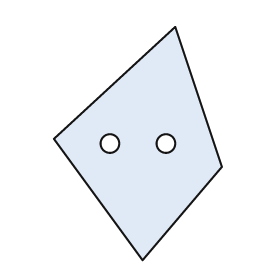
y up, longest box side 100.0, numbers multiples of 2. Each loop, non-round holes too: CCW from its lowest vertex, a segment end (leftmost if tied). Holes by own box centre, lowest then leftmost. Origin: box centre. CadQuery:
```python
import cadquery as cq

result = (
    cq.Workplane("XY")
    .moveTo(2.0, -50.0)
    .lineTo(36.0, -10.0)
    .lineTo(16.0, 50.0)
    .lineTo(-36.0, 2.0)
    .close()
    .moveTo(-12.0, 0.0)
    .circle(4.0)
    .moveTo(12.0, 0.0)
    .circle(4.0)
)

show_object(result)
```